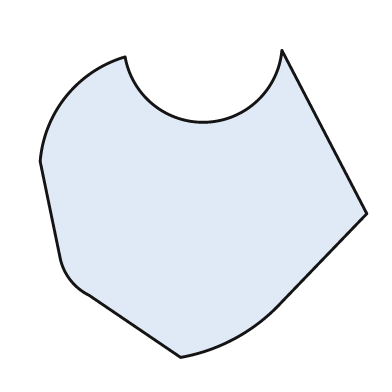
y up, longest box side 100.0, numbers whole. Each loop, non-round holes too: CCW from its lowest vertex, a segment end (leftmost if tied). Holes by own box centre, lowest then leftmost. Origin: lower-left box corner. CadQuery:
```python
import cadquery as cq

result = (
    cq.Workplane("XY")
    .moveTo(43.0, 0.0)
    .threePointArc((60.0, 6.0), (74.0, 17.0))
    .lineTo(100.0, 44.0)
    .lineTo(74.0, 94.0)
    .threePointArc((51.0, 72.0), (26.0, 92.0))
    .threePointArc((8.0, 80.0), (0.0, 60.0))
    .lineTo(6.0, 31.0)
    .threePointArc((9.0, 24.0), (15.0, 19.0))
    .close()
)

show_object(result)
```